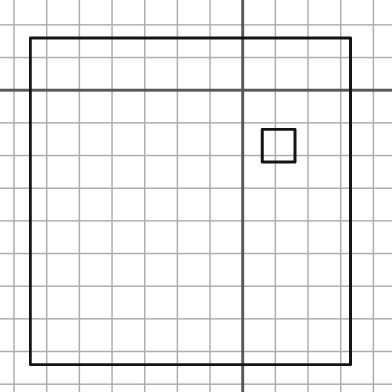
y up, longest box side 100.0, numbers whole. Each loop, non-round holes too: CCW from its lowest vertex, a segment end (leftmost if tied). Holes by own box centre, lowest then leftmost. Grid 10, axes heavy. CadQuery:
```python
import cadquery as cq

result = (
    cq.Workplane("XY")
    .moveTo(-65.0, -84.0)
    .lineTo(33.0, -84.0)
    .lineTo(33.0, 16.0)
    .lineTo(-65.0, 16.0)
    .close()
    .moveTo(6.0, -22.0)
    .lineTo(16.0, -22.0)
    .lineTo(16.0, -12.0)
    .lineTo(6.0, -12.0)
    .close()
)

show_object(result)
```